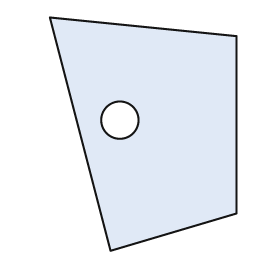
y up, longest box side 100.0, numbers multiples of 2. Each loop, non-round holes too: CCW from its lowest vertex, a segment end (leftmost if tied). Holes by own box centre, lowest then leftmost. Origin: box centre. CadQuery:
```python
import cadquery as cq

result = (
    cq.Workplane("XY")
    .moveTo(-14.0, -50.0)
    .lineTo(40.0, -34.0)
    .lineTo(40.0, 42.0)
    .lineTo(-40.0, 50.0)
    .close()
    .moveTo(-10.0, 6.0)
    .circle(8.0)
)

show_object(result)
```